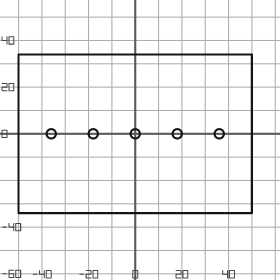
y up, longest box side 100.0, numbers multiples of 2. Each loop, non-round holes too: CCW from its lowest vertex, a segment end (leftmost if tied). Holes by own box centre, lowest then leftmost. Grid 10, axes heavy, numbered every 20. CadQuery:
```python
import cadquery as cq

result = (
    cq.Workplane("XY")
    .moveTo(-50.0, -34.0)
    .lineTo(50.0, -34.0)
    .lineTo(50.0, 34.0)
    .lineTo(-50.0, 34.0)
    .close()
    .moveTo(-36.0, 0.0)
    .circle(2.0)
    .moveTo(-18.0, 0.0)
    .circle(2.0)
    .moveTo(0.0, 0.0)
    .circle(2.0)
    .moveTo(18.0, 0.0)
    .circle(2.0)
    .moveTo(36.0, 0.0)
    .circle(2.0)
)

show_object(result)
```